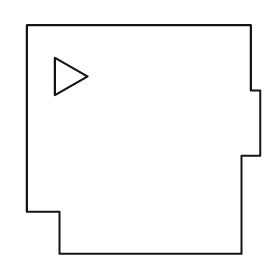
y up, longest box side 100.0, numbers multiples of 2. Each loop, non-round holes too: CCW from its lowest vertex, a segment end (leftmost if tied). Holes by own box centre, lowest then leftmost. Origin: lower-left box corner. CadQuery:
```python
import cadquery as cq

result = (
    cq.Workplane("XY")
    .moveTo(14.0, 0.0)
    .lineTo(92.0, 0.0)
    .lineTo(92.0, 42.0)
    .lineTo(100.0, 42.0)
    .lineTo(100.0, 70.0)
    .lineTo(96.0, 70.0)
    .lineTo(96.0, 98.0)
    .lineTo(0.0, 98.0)
    .lineTo(0.0, 18.0)
    .lineTo(14.0, 18.0)
    .close()
    .moveTo(12.0, 68.0)
    .lineTo(26.0, 76.0)
    .lineTo(12.0, 84.0)
    .close()
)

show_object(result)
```